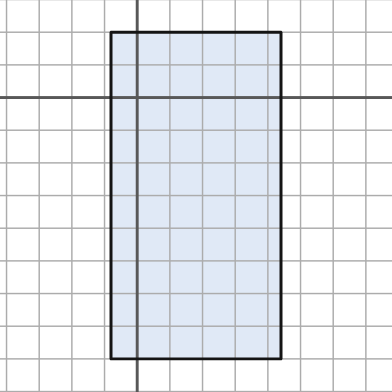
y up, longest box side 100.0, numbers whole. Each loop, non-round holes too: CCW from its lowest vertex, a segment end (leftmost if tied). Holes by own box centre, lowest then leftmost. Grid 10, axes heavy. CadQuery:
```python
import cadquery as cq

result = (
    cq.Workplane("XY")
    .moveTo(-8.0, -80.0)
    .lineTo(44.0, -80.0)
    .lineTo(44.0, 20.0)
    .lineTo(-8.0, 20.0)
    .close()
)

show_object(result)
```